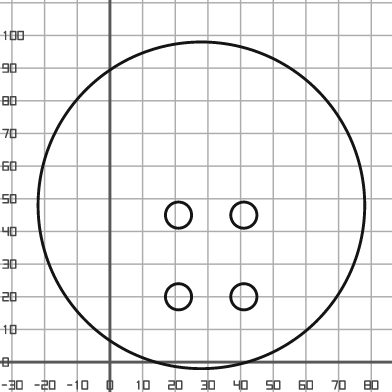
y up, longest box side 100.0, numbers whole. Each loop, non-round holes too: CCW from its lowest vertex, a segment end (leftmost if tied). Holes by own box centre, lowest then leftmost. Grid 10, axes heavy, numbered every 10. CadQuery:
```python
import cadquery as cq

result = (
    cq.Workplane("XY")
    .moveTo(28.0, 48.0)
    .circle(50.0)
    .moveTo(21.0, 20.0)
    .circle(4.0)
    .moveTo(41.0, 20.0)
    .circle(4.0)
    .moveTo(21.0, 45.0)
    .circle(4.0)
    .moveTo(41.0, 45.0)
    .circle(4.0)
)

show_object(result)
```